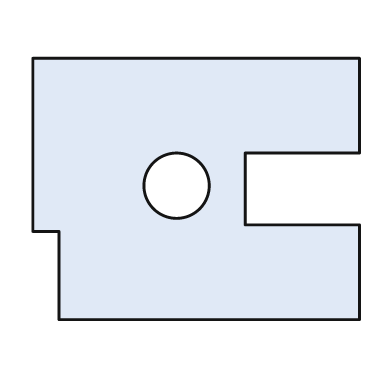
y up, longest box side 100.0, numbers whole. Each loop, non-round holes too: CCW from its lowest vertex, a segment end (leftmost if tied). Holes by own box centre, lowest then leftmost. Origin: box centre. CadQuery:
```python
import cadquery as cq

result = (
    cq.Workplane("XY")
    .moveTo(-42.0, -40.0)
    .lineTo(50.0, -40.0)
    .lineTo(50.0, -11.0)
    .lineTo(15.0, -11.0)
    .lineTo(15.0, 11.0)
    .lineTo(50.0, 11.0)
    .lineTo(50.0, 40.0)
    .lineTo(-50.0, 40.0)
    .lineTo(-50.0, -13.0)
    .lineTo(-42.0, -13.0)
    .close()
    .moveTo(-6.0, 1.0)
    .circle(10.0)
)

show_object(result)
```